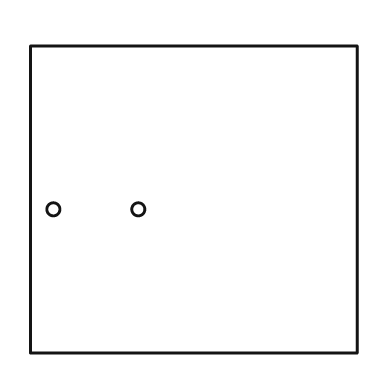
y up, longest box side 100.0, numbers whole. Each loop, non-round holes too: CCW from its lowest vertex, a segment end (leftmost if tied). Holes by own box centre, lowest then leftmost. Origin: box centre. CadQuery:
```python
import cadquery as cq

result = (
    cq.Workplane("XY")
    .moveTo(-50.0, -47.0)
    .lineTo(50.0, -47.0)
    .lineTo(50.0, 47.0)
    .lineTo(-50.0, 47.0)
    .close()
    .moveTo(-43.0, -3.0)
    .circle(2.0)
    .moveTo(-17.0, -3.0)
    .circle(2.0)
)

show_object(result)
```